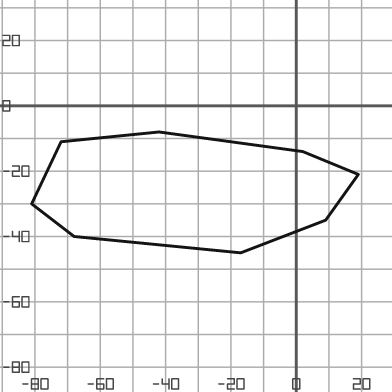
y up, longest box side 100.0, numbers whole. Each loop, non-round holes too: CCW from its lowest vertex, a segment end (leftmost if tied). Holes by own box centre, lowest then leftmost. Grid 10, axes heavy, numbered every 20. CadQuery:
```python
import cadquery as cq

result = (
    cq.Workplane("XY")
    .moveTo(-17.0, -45.0)
    .lineTo(9.0, -35.0)
    .lineTo(19.0, -21.0)
    .lineTo(2.0, -14.0)
    .lineTo(-42.0, -8.0)
    .lineTo(-72.0, -11.0)
    .lineTo(-81.0, -30.0)
    .lineTo(-68.0, -40.0)
    .close()
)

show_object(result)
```